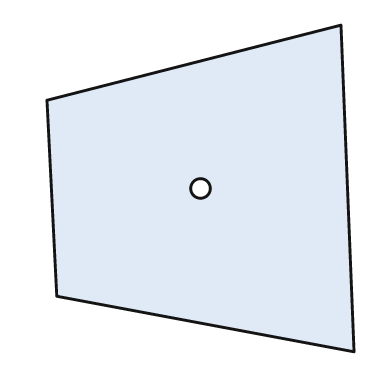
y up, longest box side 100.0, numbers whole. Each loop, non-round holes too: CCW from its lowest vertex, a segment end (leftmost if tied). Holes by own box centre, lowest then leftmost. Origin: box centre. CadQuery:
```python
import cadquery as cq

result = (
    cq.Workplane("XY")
    .moveTo(47.0, -50.0)
    .lineTo(43.0, 50.0)
    .lineTo(-47.0, 27.0)
    .lineTo(-44.0, -33.0)
    .close()
    .moveTo(0.0, 0.0)
    .circle(3.0)
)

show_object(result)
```